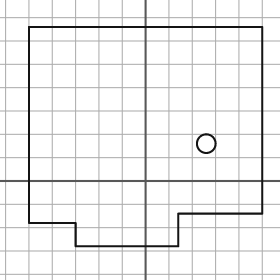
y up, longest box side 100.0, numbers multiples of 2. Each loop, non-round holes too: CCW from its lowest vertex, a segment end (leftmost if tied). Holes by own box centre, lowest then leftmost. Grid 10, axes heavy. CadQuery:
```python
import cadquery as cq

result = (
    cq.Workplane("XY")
    .moveTo(-30.0, -28.0)
    .lineTo(14.0, -28.0)
    .lineTo(14.0, -14.0)
    .lineTo(50.0, -14.0)
    .lineTo(50.0, 66.0)
    .lineTo(-50.0, 66.0)
    .lineTo(-50.0, -18.0)
    .lineTo(-30.0, -18.0)
    .close()
    .moveTo(26.0, 16.0)
    .circle(4.0)
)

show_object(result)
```